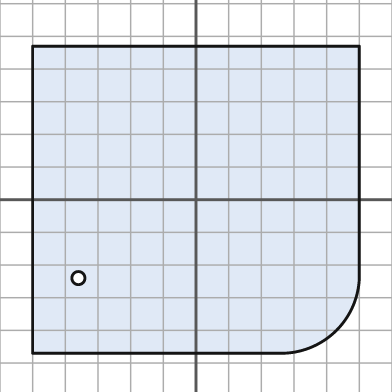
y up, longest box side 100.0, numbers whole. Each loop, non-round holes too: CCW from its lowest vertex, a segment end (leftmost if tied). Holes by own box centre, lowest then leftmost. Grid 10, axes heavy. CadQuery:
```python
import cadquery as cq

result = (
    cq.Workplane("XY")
    .moveTo(-50.0, -47.0)
    .lineTo(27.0, -47.0)
    .threePointArc((43.0, -40.0), (50.0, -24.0))
    .lineTo(50.0, 47.0)
    .lineTo(-50.0, 47.0)
    .close()
    .moveTo(-36.0, -24.0)
    .circle(2.0)
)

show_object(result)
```